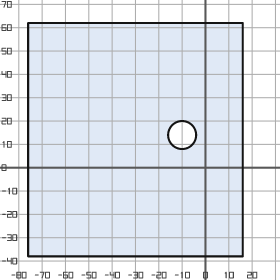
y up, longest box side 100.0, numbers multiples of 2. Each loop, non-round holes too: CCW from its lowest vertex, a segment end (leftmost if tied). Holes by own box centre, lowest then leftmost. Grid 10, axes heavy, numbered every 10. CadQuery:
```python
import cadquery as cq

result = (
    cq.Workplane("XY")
    .moveTo(-76.0, -38.0)
    .lineTo(16.0, -38.0)
    .lineTo(16.0, 62.0)
    .lineTo(-76.0, 62.0)
    .close()
    .moveTo(-10.0, 14.0)
    .circle(6.0)
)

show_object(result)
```